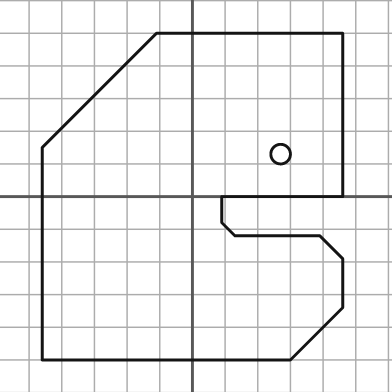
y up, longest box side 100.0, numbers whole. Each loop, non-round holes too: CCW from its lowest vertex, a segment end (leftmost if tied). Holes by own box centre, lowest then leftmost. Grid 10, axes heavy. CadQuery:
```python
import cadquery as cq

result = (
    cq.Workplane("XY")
    .moveTo(-46.0, -50.0)
    .lineTo(30.0, -50.0)
    .lineTo(46.0, -34.0)
    .lineTo(46.0, -19.0)
    .lineTo(39.0, -12.0)
    .lineTo(13.0, -12.0)
    .lineTo(9.0, -8.0)
    .lineTo(9.0, 0.0)
    .lineTo(46.0, 0.0)
    .lineTo(46.0, 50.0)
    .lineTo(-11.0, 50.0)
    .lineTo(-46.0, 15.0)
    .close()
    .moveTo(27.0, 13.0)
    .circle(3.0)
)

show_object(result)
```